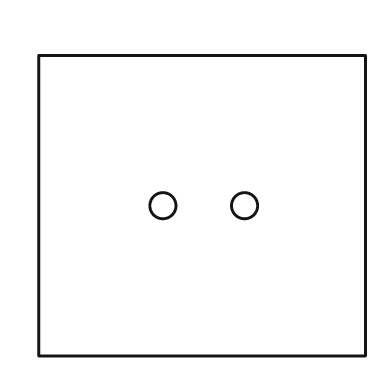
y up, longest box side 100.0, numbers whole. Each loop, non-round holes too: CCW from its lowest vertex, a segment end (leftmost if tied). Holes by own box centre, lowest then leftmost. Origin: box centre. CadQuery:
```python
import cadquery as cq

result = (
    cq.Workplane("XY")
    .moveTo(-50.0, -46.0)
    .lineTo(50.0, -46.0)
    .lineTo(50.0, 46.0)
    .lineTo(-50.0, 46.0)
    .close()
    .moveTo(-12.0, 0.0)
    .circle(4.0)
    .moveTo(13.0, 0.0)
    .circle(4.0)
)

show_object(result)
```